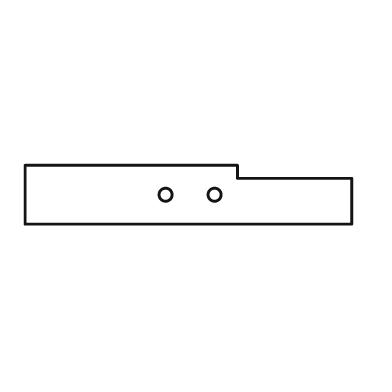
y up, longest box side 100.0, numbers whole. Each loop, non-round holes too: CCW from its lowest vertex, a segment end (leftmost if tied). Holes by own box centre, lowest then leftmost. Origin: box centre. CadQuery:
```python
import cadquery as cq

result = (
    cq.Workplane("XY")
    .moveTo(-50.0, -9.0)
    .lineTo(50.0, -9.0)
    .lineTo(50.0, 5.0)
    .lineTo(15.0, 5.0)
    .lineTo(15.0, 9.0)
    .lineTo(-50.0, 9.0)
    .close()
    .moveTo(-7.0, 0.0)
    .circle(2.0)
    .moveTo(8.0, 0.0)
    .circle(2.0)
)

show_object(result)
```